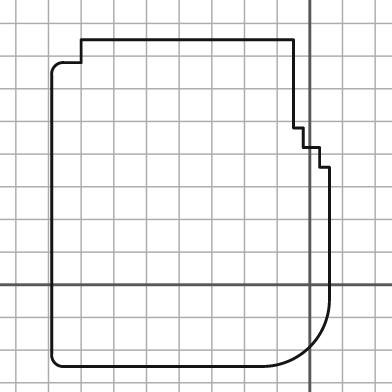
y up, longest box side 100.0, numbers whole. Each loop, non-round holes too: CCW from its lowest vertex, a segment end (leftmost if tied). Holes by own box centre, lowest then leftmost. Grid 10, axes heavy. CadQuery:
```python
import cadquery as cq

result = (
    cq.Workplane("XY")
    .moveTo(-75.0, -25.0)
    .lineTo(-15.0, -25.0)
    .threePointArc((0.0, -19.0), (6.0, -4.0))
    .lineTo(6.0, 36.0)
    .lineTo(3.0, 36.0)
    .lineTo(3.0, 42.0)
    .lineTo(-2.0, 42.0)
    .lineTo(-2.0, 48.0)
    .lineTo(-5.0, 48.0)
    .lineTo(-5.0, 75.0)
    .lineTo(-70.0, 75.0)
    .lineTo(-70.0, 68.0)
    .lineTo(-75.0, 68.0)
    .threePointArc((-78.0, 67.0), (-79.0, 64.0))
    .lineTo(-79.0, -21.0)
    .threePointArc((-78.0, -24.0), (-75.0, -25.0))
    .close()
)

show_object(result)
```